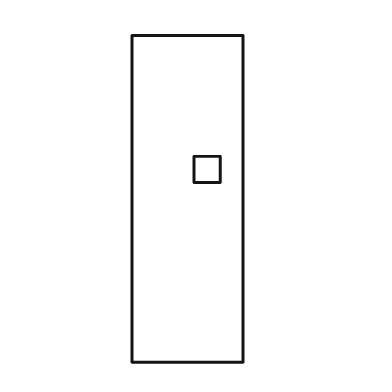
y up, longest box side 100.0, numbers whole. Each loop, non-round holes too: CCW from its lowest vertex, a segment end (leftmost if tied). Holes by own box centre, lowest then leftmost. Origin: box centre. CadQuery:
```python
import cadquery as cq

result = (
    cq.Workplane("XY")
    .moveTo(-17.0, -50.0)
    .lineTo(17.0, -50.0)
    .lineTo(17.0, 50.0)
    .lineTo(-17.0, 50.0)
    .close()
    .moveTo(2.0, 5.0)
    .lineTo(10.0, 5.0)
    .lineTo(10.0, 13.0)
    .lineTo(2.0, 13.0)
    .close()
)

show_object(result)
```